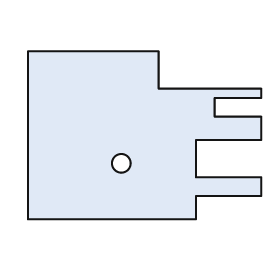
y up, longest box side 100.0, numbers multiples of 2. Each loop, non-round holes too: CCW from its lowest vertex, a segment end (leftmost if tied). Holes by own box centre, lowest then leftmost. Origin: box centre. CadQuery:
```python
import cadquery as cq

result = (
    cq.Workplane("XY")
    .moveTo(-50.0, -36.0)
    .lineTo(22.0, -36.0)
    .lineTo(22.0, -26.0)
    .lineTo(50.0, -26.0)
    .lineTo(50.0, -18.0)
    .lineTo(22.0, -18.0)
    .lineTo(22.0, -2.0)
    .lineTo(50.0, -2.0)
    .lineTo(50.0, 8.0)
    .lineTo(30.0, 8.0)
    .lineTo(30.0, 16.0)
    .lineTo(50.0, 16.0)
    .lineTo(50.0, 20.0)
    .lineTo(6.0, 20.0)
    .lineTo(6.0, 36.0)
    .lineTo(-50.0, 36.0)
    .close()
    .moveTo(-10.0, -12.0)
    .circle(4.0)
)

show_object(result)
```